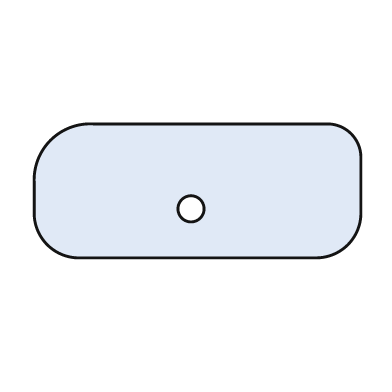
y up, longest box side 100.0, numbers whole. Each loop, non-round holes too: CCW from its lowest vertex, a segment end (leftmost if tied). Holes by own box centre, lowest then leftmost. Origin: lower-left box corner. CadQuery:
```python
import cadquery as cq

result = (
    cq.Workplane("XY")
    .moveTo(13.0, 0.0)
    .lineTo(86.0, 0.0)
    .threePointArc((96.0, 4.0), (100.0, 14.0))
    .lineTo(100.0, 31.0)
    .threePointArc((97.0, 38.0), (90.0, 41.0))
    .lineTo(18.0, 41.0)
    .threePointArc((5.0, 36.0), (0.0, 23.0))
    .lineTo(0.0, 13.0)
    .threePointArc((4.0, 4.0), (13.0, 0.0))
    .close()
    .moveTo(48.0, 15.0)
    .circle(4.0)
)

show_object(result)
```